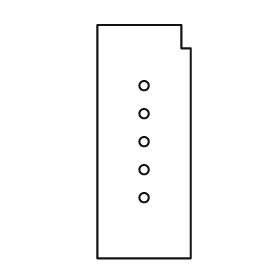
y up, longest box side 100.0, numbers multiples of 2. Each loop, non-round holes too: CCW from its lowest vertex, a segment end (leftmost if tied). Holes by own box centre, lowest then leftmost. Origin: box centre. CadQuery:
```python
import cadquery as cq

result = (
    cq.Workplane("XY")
    .moveTo(-20.0, -50.0)
    .lineTo(20.0, -50.0)
    .lineTo(20.0, 40.0)
    .lineTo(16.0, 40.0)
    .lineTo(16.0, 50.0)
    .lineTo(-20.0, 50.0)
    .close()
    .moveTo(0.0, -24.0)
    .circle(2.0)
    .moveTo(0.0, -12.0)
    .circle(2.0)
    .moveTo(0.0, 0.0)
    .circle(2.0)
    .moveTo(0.0, 12.0)
    .circle(2.0)
    .moveTo(0.0, 24.0)
    .circle(2.0)
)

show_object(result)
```